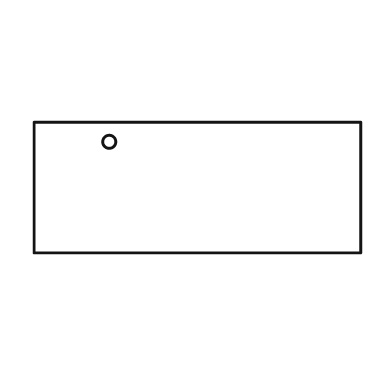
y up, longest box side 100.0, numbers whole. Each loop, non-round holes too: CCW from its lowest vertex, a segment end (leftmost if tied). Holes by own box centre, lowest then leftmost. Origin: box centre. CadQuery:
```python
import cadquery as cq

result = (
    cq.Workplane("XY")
    .moveTo(-50.0, -20.0)
    .lineTo(50.0, -20.0)
    .lineTo(50.0, 20.0)
    .lineTo(-50.0, 20.0)
    .close()
    .moveTo(-27.0, 14.0)
    .circle(2.0)
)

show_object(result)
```